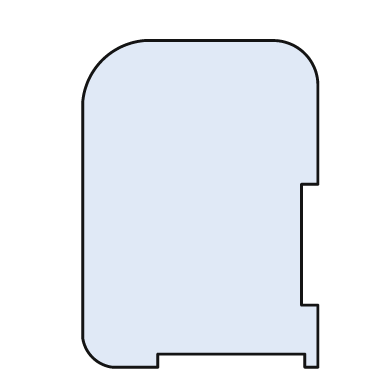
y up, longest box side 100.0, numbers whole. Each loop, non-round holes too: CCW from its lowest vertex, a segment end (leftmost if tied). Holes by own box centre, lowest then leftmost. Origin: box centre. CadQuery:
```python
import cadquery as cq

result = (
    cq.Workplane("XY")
    .moveTo(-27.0, -50.0)
    .lineTo(-13.0, -50.0)
    .lineTo(-13.0, -46.0)
    .lineTo(32.0, -46.0)
    .lineTo(32.0, -50.0)
    .lineTo(36.0, -50.0)
    .lineTo(36.0, -31.0)
    .lineTo(31.0, -31.0)
    .lineTo(31.0, 6.0)
    .lineTo(36.0, 6.0)
    .lineTo(36.0, 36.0)
    .threePointArc((32.0, 46.0), (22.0, 50.0))
    .lineTo(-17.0, 50.0)
    .threePointArc((-30.0, 44.0), (-36.0, 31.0))
    .lineTo(-36.0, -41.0)
    .threePointArc((-33.0, -47.0), (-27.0, -50.0))
    .close()
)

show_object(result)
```